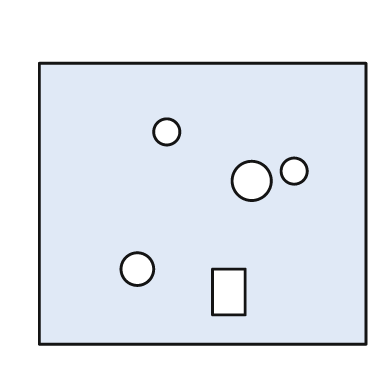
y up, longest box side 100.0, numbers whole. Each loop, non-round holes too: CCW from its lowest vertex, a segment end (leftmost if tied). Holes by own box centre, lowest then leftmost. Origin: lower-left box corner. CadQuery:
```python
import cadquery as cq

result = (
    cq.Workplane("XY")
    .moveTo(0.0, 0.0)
    .lineTo(100.0, 0.0)
    .lineTo(100.0, 86.0)
    .lineTo(0.0, 86.0)
    .close()
    .moveTo(53.0, 9.0)
    .lineTo(63.0, 9.0)
    .lineTo(63.0, 23.0)
    .lineTo(53.0, 23.0)
    .close()
    .moveTo(30.0, 23.0)
    .circle(5.0)
    .moveTo(65.0, 50.0)
    .circle(6.0)
    .moveTo(78.0, 53.0)
    .circle(4.0)
    .moveTo(39.0, 65.0)
    .circle(4.0)
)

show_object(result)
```